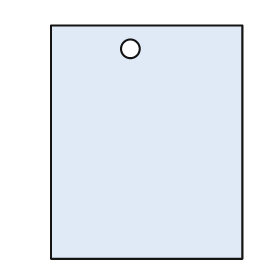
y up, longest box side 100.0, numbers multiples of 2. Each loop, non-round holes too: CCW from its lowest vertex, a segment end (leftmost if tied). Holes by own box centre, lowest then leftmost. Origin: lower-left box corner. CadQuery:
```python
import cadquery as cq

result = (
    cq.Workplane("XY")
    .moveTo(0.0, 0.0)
    .lineTo(82.0, 0.0)
    .lineTo(82.0, 100.0)
    .lineTo(0.0, 100.0)
    .close()
    .moveTo(34.0, 90.0)
    .circle(4.0)
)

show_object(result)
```